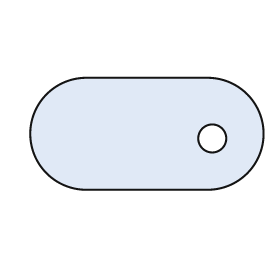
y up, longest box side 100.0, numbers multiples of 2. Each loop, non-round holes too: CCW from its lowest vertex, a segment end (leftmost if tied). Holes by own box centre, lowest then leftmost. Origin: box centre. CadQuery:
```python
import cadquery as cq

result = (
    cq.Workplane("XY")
    .moveTo(-26.0, -24.0)
    .lineTo(26.0, -24.0)
    .threePointArc((50.0, 0.0), (26.0, 24.0))
    .lineTo(-26.0, 24.0)
    .threePointArc((-50.0, 0.0), (-26.0, -24.0))
    .close()
    .moveTo(28.0, -2.0)
    .circle(6.0)
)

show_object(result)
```